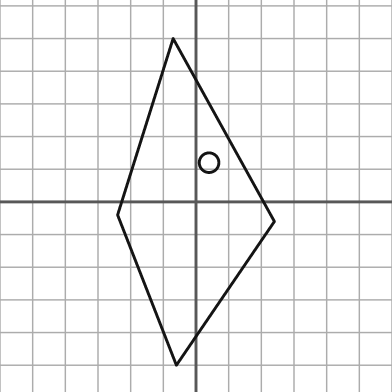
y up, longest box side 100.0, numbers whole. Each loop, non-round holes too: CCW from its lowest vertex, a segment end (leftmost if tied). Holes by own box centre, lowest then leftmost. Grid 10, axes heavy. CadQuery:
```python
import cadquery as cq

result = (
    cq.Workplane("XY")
    .moveTo(-6.0, -50.0)
    .lineTo(24.0, -6.0)
    .lineTo(-7.0, 50.0)
    .lineTo(-24.0, -4.0)
    .close()
    .moveTo(4.0, 12.0)
    .circle(3.0)
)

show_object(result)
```